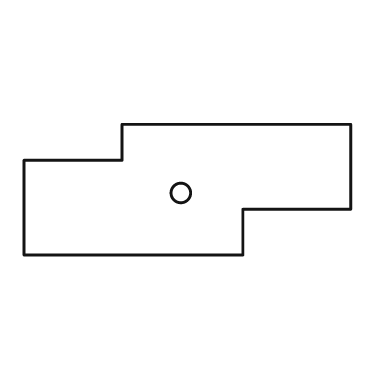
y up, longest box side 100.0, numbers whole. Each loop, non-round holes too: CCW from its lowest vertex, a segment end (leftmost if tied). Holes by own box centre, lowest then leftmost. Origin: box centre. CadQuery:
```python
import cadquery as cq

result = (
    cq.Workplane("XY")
    .moveTo(-50.0, -20.0)
    .lineTo(17.0, -20.0)
    .lineTo(17.0, -6.0)
    .lineTo(50.0, -6.0)
    .lineTo(50.0, 20.0)
    .lineTo(-20.0, 20.0)
    .lineTo(-20.0, 9.0)
    .lineTo(-50.0, 9.0)
    .close()
    .moveTo(-2.0, -1.0)
    .circle(3.0)
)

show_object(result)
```